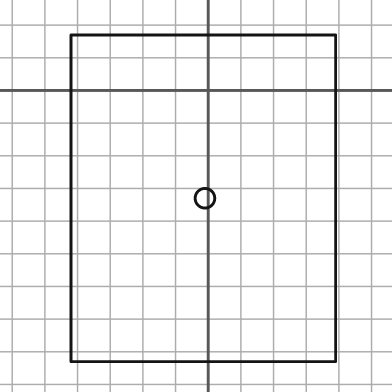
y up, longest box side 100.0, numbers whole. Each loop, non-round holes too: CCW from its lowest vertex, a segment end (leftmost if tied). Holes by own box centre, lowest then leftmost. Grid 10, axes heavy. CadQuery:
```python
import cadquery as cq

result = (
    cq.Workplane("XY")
    .moveTo(-42.0, -83.0)
    .lineTo(39.0, -83.0)
    .lineTo(39.0, 17.0)
    .lineTo(-42.0, 17.0)
    .close()
    .moveTo(-1.0, -33.0)
    .circle(3.0)
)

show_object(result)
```